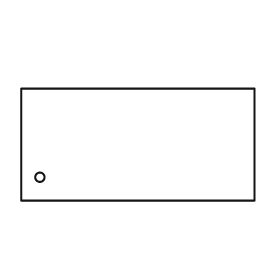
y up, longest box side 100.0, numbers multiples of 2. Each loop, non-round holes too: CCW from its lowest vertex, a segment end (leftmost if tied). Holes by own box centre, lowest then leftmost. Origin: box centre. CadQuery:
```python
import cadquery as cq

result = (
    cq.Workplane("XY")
    .moveTo(-50.0, -24.0)
    .lineTo(50.0, -24.0)
    .lineTo(50.0, 24.0)
    .lineTo(-50.0, 24.0)
    .close()
    .moveTo(-42.0, -14.0)
    .circle(2.0)
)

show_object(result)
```